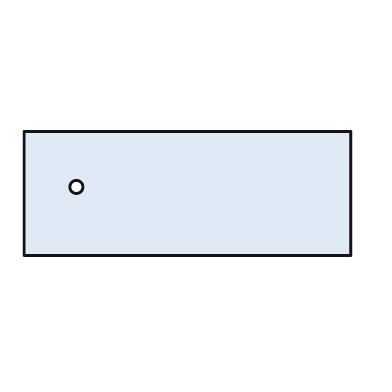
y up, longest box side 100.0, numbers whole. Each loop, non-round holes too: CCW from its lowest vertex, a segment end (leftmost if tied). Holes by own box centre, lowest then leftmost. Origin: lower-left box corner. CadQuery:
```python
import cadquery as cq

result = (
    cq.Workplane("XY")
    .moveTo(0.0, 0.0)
    .lineTo(100.0, 0.0)
    .lineTo(100.0, 38.0)
    .lineTo(0.0, 38.0)
    .close()
    .moveTo(16.0, 21.0)
    .circle(2.0)
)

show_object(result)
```